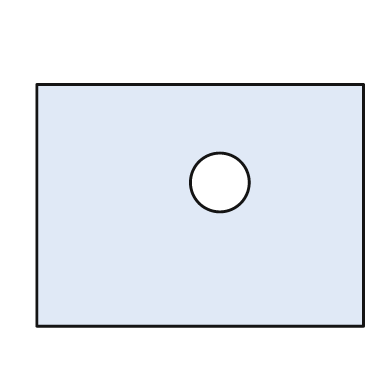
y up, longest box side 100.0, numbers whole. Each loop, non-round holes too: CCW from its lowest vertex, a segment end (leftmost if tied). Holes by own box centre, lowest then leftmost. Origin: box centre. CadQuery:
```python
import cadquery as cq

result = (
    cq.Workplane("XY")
    .moveTo(-50.0, -37.0)
    .lineTo(50.0, -37.0)
    .lineTo(50.0, 37.0)
    .lineTo(-50.0, 37.0)
    .close()
    .moveTo(6.0, 7.0)
    .circle(9.0)
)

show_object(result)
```